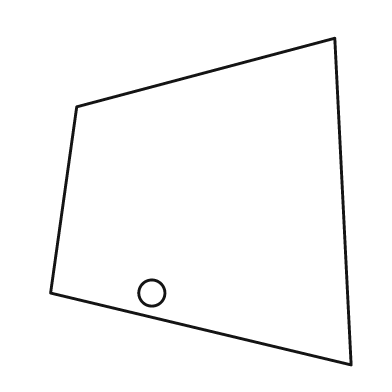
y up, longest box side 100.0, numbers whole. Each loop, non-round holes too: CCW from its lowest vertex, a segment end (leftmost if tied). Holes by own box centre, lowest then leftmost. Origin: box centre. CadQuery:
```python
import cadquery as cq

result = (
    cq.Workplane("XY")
    .moveTo(46.0, -50.0)
    .lineTo(41.0, 50.0)
    .lineTo(-38.0, 29.0)
    .lineTo(-46.0, -28.0)
    .close()
    .moveTo(-15.0, -28.0)
    .circle(4.0)
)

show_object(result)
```